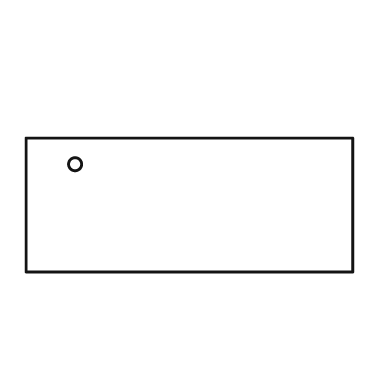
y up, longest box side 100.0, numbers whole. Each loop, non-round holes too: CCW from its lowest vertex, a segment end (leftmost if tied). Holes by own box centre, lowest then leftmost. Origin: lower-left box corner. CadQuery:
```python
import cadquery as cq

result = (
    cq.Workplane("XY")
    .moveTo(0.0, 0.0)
    .lineTo(100.0, 0.0)
    .lineTo(100.0, 41.0)
    .lineTo(0.0, 41.0)
    .close()
    .moveTo(15.0, 33.0)
    .circle(2.0)
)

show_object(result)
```